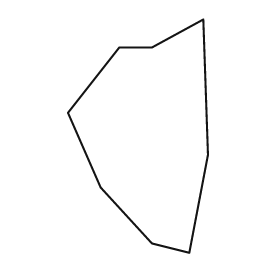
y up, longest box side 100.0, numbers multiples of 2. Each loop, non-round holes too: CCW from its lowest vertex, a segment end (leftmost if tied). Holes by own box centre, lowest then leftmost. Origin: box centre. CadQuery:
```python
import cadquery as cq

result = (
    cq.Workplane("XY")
    .moveTo(22.0, -50.0)
    .lineTo(30.0, -8.0)
    .lineTo(28.0, 50.0)
    .lineTo(6.0, 38.0)
    .lineTo(-8.0, 38.0)
    .lineTo(-30.0, 10.0)
    .lineTo(-16.0, -22.0)
    .lineTo(6.0, -46.0)
    .close()
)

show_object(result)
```